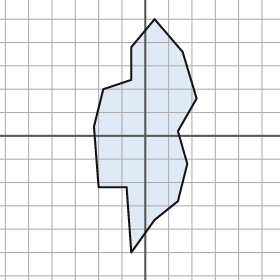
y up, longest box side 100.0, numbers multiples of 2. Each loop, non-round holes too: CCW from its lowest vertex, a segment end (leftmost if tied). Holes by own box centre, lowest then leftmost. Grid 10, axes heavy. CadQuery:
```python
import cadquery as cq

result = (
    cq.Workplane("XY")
    .moveTo(-6.0, -50.0)
    .lineTo(4.0, -36.0)
    .lineTo(14.0, -28.0)
    .lineTo(18.0, -12.0)
    .lineTo(14.0, 2.0)
    .lineTo(22.0, 16.0)
    .lineTo(16.0, 36.0)
    .lineTo(4.0, 50.0)
    .lineTo(-6.0, 38.0)
    .lineTo(-6.0, 24.0)
    .lineTo(-18.0, 20.0)
    .lineTo(-22.0, 4.0)
    .lineTo(-20.0, -22.0)
    .lineTo(-8.0, -22.0)
    .close()
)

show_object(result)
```